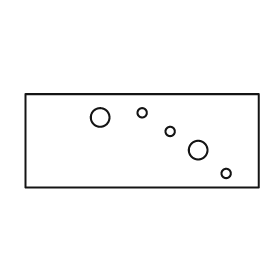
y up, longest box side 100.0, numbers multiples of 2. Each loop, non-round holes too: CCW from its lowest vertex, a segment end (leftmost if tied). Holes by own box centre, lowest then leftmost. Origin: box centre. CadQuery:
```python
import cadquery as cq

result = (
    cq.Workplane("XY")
    .moveTo(-50.0, -20.0)
    .lineTo(50.0, -20.0)
    .lineTo(50.0, 20.0)
    .lineTo(-50.0, 20.0)
    .close()
    .moveTo(36.0, -14.0)
    .circle(2.0)
    .moveTo(24.0, -4.0)
    .circle(4.0)
    .moveTo(12.0, 4.0)
    .circle(2.0)
    .moveTo(-18.0, 10.0)
    .circle(4.0)
    .moveTo(0.0, 12.0)
    .circle(2.0)
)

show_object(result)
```